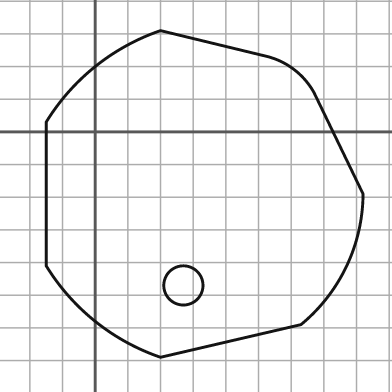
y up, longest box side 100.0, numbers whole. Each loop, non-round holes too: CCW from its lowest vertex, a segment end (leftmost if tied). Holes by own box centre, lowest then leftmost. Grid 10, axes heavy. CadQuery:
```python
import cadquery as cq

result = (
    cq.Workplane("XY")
    .moveTo(20.0, -69.0)
    .lineTo(63.0, -59.0)
    .threePointArc((77.0, -41.0), (82.0, -19.0))
    .lineTo(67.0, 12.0)
    .threePointArc((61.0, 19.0), (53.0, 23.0))
    .lineTo(20.0, 31.0)
    .threePointArc((0.0, 20.0), (-15.0, 3.0))
    .lineTo(-15.0, -41.0)
    .threePointArc((0.0, -58.0), (20.0, -69.0))
    .close()
    .moveTo(27.0, -47.0)
    .circle(6.0)
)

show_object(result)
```